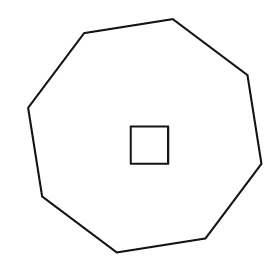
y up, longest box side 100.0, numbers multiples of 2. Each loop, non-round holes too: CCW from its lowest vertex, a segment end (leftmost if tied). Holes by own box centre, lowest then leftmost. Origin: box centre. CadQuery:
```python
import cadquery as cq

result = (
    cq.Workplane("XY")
    .moveTo(-12.0, -50.0)
    .lineTo(26.0, -44.0)
    .lineTo(50.0, -12.0)
    .lineTo(44.0, 26.0)
    .lineTo(12.0, 50.0)
    .lineTo(-26.0, 44.0)
    .lineTo(-50.0, 12.0)
    .lineTo(-44.0, -26.0)
    .close()
    .moveTo(-6.0, -12.0)
    .lineTo(10.0, -12.0)
    .lineTo(10.0, 4.0)
    .lineTo(-6.0, 4.0)
    .close()
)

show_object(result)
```